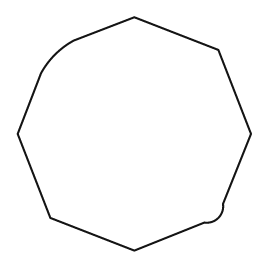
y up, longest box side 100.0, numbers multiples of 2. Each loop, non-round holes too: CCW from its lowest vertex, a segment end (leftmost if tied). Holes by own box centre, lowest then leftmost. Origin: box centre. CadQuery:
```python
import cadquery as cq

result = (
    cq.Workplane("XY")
    .moveTo(0.0, -50.0)
    .lineTo(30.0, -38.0)
    .threePointArc((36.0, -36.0), (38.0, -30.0))
    .lineTo(50.0, 0.0)
    .lineTo(36.0, 36.0)
    .lineTo(0.0, 50.0)
    .lineTo(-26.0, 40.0)
    .threePointArc((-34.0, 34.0), (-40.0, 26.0))
    .lineTo(-50.0, 0.0)
    .lineTo(-36.0, -36.0)
    .close()
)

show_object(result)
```